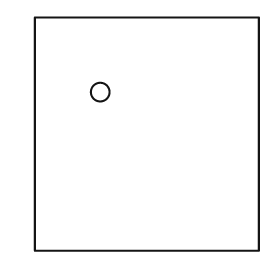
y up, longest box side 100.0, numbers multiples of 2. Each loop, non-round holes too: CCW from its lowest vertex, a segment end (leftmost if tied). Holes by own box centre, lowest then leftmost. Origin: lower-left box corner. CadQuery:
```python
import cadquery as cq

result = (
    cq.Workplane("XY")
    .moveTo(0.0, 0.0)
    .lineTo(96.0, 0.0)
    .lineTo(96.0, 100.0)
    .lineTo(0.0, 100.0)
    .close()
    .moveTo(28.0, 68.0)
    .circle(4.0)
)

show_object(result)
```